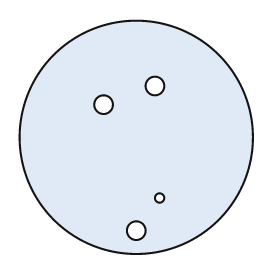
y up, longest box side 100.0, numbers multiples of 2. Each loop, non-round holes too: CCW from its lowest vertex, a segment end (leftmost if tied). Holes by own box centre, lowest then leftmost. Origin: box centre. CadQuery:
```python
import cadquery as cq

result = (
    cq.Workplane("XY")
    .moveTo(0.0, 0.0)
    .circle(50.0)
    .moveTo(0.0, -40.0)
    .circle(4.0)
    .moveTo(10.0, -26.0)
    .circle(2.0)
    .moveTo(-14.0, 14.0)
    .circle(4.0)
    .moveTo(8.0, 22.0)
    .circle(4.0)
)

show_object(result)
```